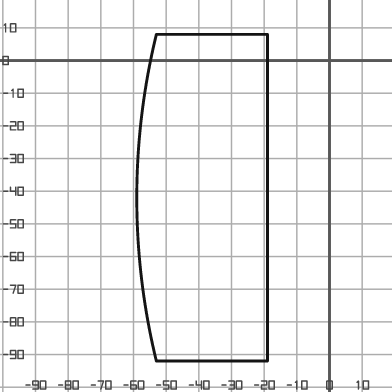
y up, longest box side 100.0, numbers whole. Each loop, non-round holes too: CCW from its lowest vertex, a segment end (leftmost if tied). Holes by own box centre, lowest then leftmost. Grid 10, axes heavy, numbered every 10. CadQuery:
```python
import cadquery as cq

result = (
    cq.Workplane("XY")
    .moveTo(-53.0, -92.0)
    .lineTo(-19.0, -92.0)
    .lineTo(-19.0, 8.0)
    .lineTo(-53.0, 8.0)
    .threePointArc((-59.0, -42.0), (-53.0, -92.0))
    .close()
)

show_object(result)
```